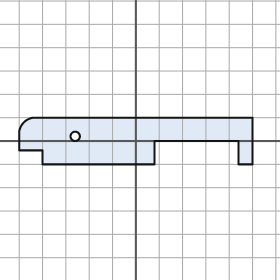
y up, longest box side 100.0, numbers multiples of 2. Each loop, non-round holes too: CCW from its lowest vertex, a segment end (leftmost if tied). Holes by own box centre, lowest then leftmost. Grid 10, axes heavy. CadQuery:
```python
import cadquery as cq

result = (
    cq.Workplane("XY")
    .moveTo(-40.0, -10.0)
    .lineTo(8.0, -10.0)
    .lineTo(8.0, 0.0)
    .lineTo(44.0, 0.0)
    .lineTo(44.0, -10.0)
    .lineTo(50.0, -10.0)
    .lineTo(50.0, 10.0)
    .lineTo(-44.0, 10.0)
    .threePointArc((-48.0, 8.0), (-50.0, 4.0))
    .lineTo(-50.0, -4.0)
    .lineTo(-40.0, -4.0)
    .close()
    .moveTo(-26.0, 2.0)
    .circle(2.0)
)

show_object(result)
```